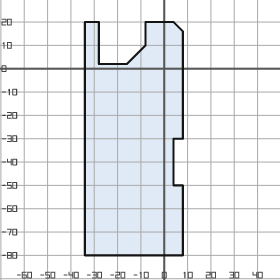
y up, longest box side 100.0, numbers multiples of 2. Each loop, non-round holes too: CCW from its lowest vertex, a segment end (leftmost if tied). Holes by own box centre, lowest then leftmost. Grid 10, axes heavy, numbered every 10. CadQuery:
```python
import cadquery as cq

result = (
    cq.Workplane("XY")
    .moveTo(-34.0, -80.0)
    .lineTo(8.0, -80.0)
    .lineTo(8.0, -50.0)
    .lineTo(4.0, -50.0)
    .lineTo(4.0, -30.0)
    .lineTo(8.0, -30.0)
    .lineTo(8.0, 16.0)
    .lineTo(4.0, 20.0)
    .lineTo(-8.0, 20.0)
    .lineTo(-8.0, 10.0)
    .lineTo(-16.0, 2.0)
    .lineTo(-28.0, 2.0)
    .lineTo(-28.0, 20.0)
    .lineTo(-34.0, 20.0)
    .close()
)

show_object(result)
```